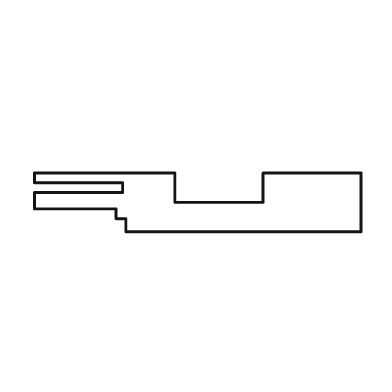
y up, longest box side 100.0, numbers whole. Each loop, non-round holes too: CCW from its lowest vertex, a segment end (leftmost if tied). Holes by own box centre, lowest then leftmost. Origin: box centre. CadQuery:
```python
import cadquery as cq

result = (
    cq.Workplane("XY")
    .moveTo(-22.0, -9.0)
    .lineTo(50.0, -9.0)
    .lineTo(50.0, 9.0)
    .lineTo(20.0, 9.0)
    .lineTo(20.0, 0.0)
    .lineTo(-7.0, 0.0)
    .lineTo(-7.0, 9.0)
    .lineTo(-50.0, 9.0)
    .lineTo(-50.0, 6.0)
    .lineTo(-23.0, 6.0)
    .lineTo(-23.0, 3.0)
    .lineTo(-50.0, 3.0)
    .lineTo(-50.0, -2.0)
    .lineTo(-25.0, -2.0)
    .lineTo(-25.0, -5.0)
    .lineTo(-22.0, -5.0)
    .close()
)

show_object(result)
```